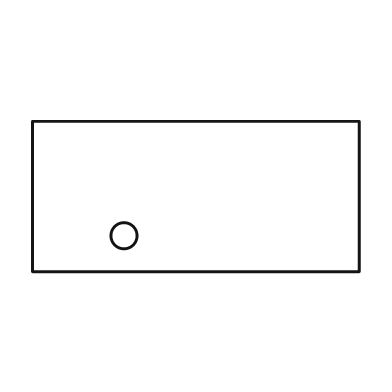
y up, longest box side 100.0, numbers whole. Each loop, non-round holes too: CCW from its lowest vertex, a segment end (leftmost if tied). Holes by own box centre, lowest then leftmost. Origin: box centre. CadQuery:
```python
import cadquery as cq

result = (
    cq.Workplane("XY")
    .moveTo(-50.0, -23.0)
    .lineTo(50.0, -23.0)
    .lineTo(50.0, 23.0)
    .lineTo(-50.0, 23.0)
    .close()
    .moveTo(-22.0, -12.0)
    .circle(4.0)
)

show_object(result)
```